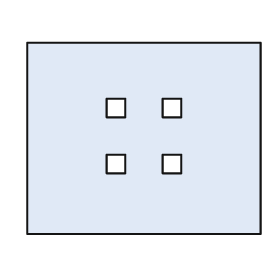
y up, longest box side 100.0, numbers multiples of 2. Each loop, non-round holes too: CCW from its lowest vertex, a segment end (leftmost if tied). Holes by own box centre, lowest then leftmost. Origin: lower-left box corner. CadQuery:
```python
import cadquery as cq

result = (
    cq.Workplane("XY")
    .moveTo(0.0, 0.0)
    .lineTo(100.0, 0.0)
    .lineTo(100.0, 82.0)
    .lineTo(0.0, 82.0)
    .close()
    .moveTo(34.0, 26.0)
    .lineTo(42.0, 26.0)
    .lineTo(42.0, 34.0)
    .lineTo(34.0, 34.0)
    .close()
    .moveTo(58.0, 26.0)
    .lineTo(66.0, 26.0)
    .lineTo(66.0, 34.0)
    .lineTo(58.0, 34.0)
    .close()
    .moveTo(34.0, 50.0)
    .lineTo(42.0, 50.0)
    .lineTo(42.0, 58.0)
    .lineTo(34.0, 58.0)
    .close()
    .moveTo(58.0, 50.0)
    .lineTo(66.0, 50.0)
    .lineTo(66.0, 58.0)
    .lineTo(58.0, 58.0)
    .close()
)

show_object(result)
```